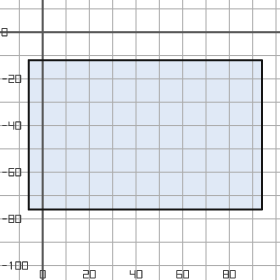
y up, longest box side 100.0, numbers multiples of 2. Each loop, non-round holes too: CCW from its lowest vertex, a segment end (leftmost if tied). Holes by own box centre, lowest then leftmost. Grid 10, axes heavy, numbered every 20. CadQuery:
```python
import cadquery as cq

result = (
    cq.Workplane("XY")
    .moveTo(-6.0, -76.0)
    .lineTo(94.0, -76.0)
    .lineTo(94.0, -12.0)
    .lineTo(-6.0, -12.0)
    .close()
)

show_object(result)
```